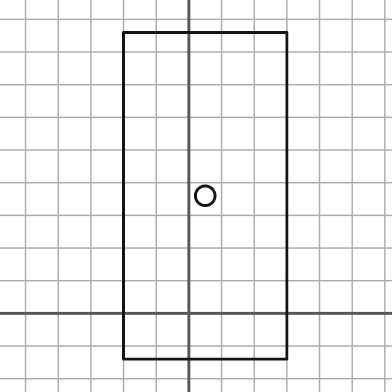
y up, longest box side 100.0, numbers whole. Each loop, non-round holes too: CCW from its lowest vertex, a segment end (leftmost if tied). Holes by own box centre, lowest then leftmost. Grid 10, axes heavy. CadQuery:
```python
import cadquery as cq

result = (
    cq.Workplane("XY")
    .moveTo(-20.0, -14.0)
    .lineTo(30.0, -14.0)
    .lineTo(30.0, 86.0)
    .lineTo(-20.0, 86.0)
    .close()
    .moveTo(5.0, 36.0)
    .circle(3.0)
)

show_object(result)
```